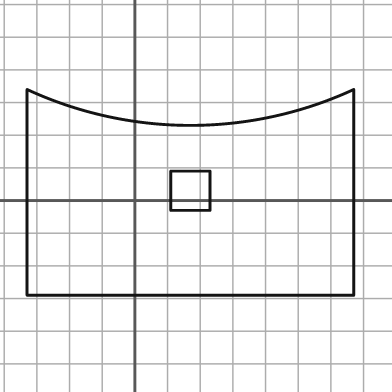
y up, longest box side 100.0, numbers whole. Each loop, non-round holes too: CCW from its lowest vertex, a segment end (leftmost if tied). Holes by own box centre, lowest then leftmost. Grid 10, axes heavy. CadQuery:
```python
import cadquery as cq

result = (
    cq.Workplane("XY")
    .moveTo(-33.0, -29.0)
    .lineTo(67.0, -29.0)
    .lineTo(67.0, 34.0)
    .threePointArc((17.0, 23.0), (-33.0, 34.0))
    .close()
    .moveTo(11.0, -3.0)
    .lineTo(23.0, -3.0)
    .lineTo(23.0, 9.0)
    .lineTo(11.0, 9.0)
    .close()
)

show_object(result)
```